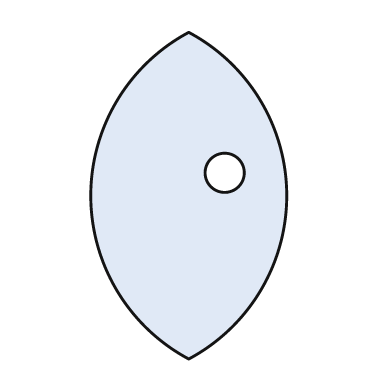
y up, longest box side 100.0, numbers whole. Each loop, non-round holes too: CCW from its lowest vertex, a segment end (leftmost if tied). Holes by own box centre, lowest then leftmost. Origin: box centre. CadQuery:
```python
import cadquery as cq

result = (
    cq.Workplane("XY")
    .moveTo(0.0, -50.0)
    .threePointArc((30.0, 0.0), (0.0, 50.0))
    .threePointArc((-30.0, 0.0), (0.0, -50.0))
    .close()
    .moveTo(11.0, 7.0)
    .circle(6.0)
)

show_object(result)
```